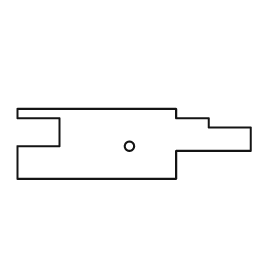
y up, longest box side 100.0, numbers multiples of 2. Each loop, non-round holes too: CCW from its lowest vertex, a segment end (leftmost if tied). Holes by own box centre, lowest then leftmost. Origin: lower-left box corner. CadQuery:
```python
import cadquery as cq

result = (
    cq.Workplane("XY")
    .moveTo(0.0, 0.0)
    .lineTo(68.0, 0.0)
    .lineTo(68.0, 12.0)
    .lineTo(100.0, 12.0)
    .lineTo(100.0, 22.0)
    .lineTo(82.0, 22.0)
    .lineTo(82.0, 26.0)
    .lineTo(68.0, 26.0)
    .lineTo(68.0, 30.0)
    .lineTo(0.0, 30.0)
    .lineTo(0.0, 26.0)
    .lineTo(18.0, 26.0)
    .lineTo(18.0, 14.0)
    .lineTo(0.0, 14.0)
    .close()
    .moveTo(48.0, 14.0)
    .circle(2.0)
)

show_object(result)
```